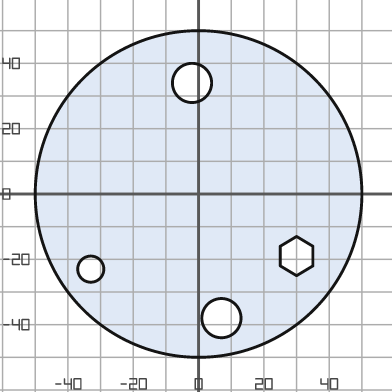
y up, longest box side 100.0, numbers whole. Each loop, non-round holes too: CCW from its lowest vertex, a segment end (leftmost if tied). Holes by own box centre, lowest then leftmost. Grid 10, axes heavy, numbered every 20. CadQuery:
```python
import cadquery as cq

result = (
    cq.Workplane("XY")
    .moveTo(0.0, 0.0)
    .circle(50.0)
    .moveTo(7.0, -38.0)
    .circle(6.0)
    .moveTo(-33.0, -23.0)
    .circle(4.0)
    .moveTo(30.0, -25.0)
    .lineTo(35.0, -22.0)
    .lineTo(35.0, -16.0)
    .lineTo(30.0, -13.0)
    .lineTo(25.0, -16.0)
    .lineTo(25.0, -22.0)
    .close()
    .moveTo(-2.0, 34.0)
    .circle(6.0)
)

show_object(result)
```